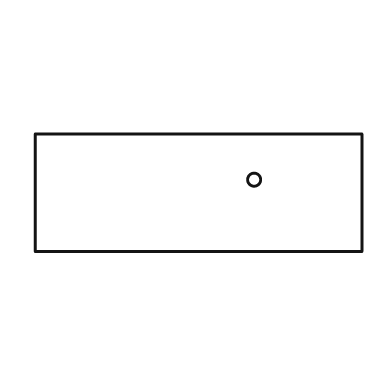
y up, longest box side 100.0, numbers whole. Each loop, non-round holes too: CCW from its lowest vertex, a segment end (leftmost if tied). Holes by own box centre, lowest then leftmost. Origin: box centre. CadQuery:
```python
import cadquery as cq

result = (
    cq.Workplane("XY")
    .moveTo(-50.0, -18.0)
    .lineTo(50.0, -18.0)
    .lineTo(50.0, 18.0)
    .lineTo(-50.0, 18.0)
    .close()
    .moveTo(17.0, 4.0)
    .circle(2.0)
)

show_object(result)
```